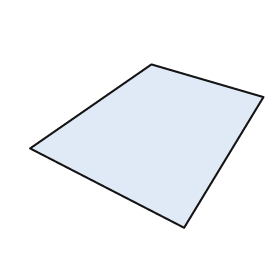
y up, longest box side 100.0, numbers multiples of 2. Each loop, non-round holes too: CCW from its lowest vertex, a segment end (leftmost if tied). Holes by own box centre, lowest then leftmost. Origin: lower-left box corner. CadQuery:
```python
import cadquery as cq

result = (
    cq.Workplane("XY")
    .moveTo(66.0, 0.0)
    .lineTo(100.0, 56.0)
    .lineTo(52.0, 70.0)
    .lineTo(0.0, 34.0)
    .close()
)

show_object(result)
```